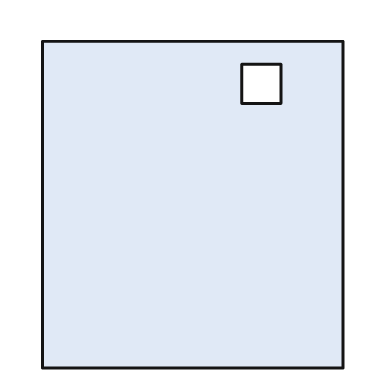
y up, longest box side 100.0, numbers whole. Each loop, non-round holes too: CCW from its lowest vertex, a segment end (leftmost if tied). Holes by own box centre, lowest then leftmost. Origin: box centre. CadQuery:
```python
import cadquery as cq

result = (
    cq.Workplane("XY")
    .moveTo(-46.0, -50.0)
    .lineTo(46.0, -50.0)
    .lineTo(46.0, 50.0)
    .lineTo(-46.0, 50.0)
    .close()
    .moveTo(15.0, 31.0)
    .lineTo(27.0, 31.0)
    .lineTo(27.0, 43.0)
    .lineTo(15.0, 43.0)
    .close()
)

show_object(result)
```